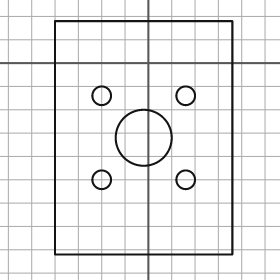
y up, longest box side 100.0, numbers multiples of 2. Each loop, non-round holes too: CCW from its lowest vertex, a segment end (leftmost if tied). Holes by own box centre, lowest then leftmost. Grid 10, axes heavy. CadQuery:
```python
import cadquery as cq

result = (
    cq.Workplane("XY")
    .moveTo(-40.0, -82.0)
    .lineTo(36.0, -82.0)
    .lineTo(36.0, 18.0)
    .lineTo(-40.0, 18.0)
    .close()
    .moveTo(-20.0, -50.0)
    .circle(4.0)
    .moveTo(16.0, -50.0)
    .circle(4.0)
    .moveTo(-2.0, -32.0)
    .circle(12.0)
    .moveTo(-20.0, -14.0)
    .circle(4.0)
    .moveTo(16.0, -14.0)
    .circle(4.0)
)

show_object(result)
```